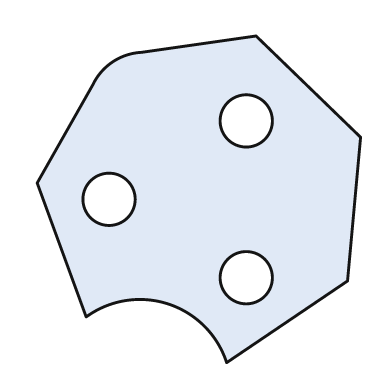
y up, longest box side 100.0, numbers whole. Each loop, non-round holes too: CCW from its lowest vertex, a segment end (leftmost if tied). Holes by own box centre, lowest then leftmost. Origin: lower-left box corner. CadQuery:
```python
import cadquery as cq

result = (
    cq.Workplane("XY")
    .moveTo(58.0, 0.0)
    .lineTo(95.0, 25.0)
    .lineTo(99.0, 69.0)
    .lineTo(67.0, 100.0)
    .lineTo(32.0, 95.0)
    .threePointArc((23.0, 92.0), (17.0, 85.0))
    .lineTo(0.0, 55.0)
    .lineTo(15.0, 14.0)
    .threePointArc((40.0, 18.0), (58.0, 0.0))
    .close()
    .moveTo(64.0, 26.0)
    .circle(8.0)
    .moveTo(22.0, 50.0)
    .circle(8.0)
    .moveTo(64.0, 74.0)
    .circle(8.0)
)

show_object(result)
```